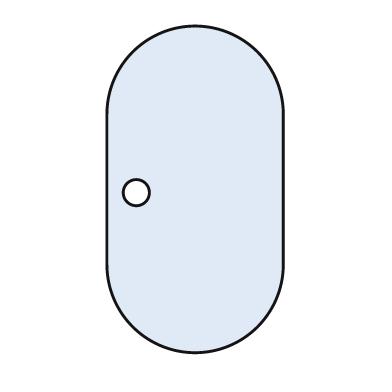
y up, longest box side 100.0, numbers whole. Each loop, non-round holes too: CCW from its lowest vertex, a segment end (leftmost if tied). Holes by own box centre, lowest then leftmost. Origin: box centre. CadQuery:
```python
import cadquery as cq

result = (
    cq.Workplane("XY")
    .moveTo(-27.0, -23.0)
    .threePointArc((0.0, -50.0), (27.0, -23.0))
    .lineTo(27.0, 23.0)
    .threePointArc((0.0, 50.0), (-27.0, 23.0))
    .close()
    .moveTo(-18.0, -1.0)
    .circle(4.0)
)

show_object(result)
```